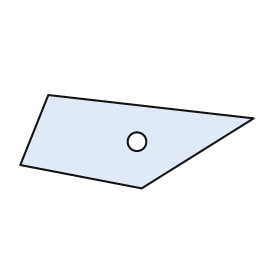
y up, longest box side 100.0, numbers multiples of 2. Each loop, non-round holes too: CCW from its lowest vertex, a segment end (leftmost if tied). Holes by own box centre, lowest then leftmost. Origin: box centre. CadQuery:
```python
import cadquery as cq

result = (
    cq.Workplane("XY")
    .moveTo(2.0, -20.0)
    .lineTo(50.0, 10.0)
    .lineTo(-38.0, 20.0)
    .lineTo(-50.0, -10.0)
    .close()
    .moveTo(0.0, 0.0)
    .circle(4.0)
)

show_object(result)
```